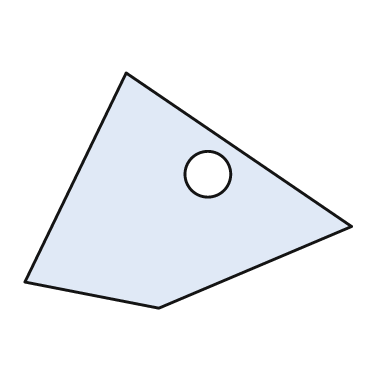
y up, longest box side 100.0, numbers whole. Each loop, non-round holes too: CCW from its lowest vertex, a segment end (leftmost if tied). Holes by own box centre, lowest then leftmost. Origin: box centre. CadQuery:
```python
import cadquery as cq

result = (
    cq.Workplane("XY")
    .moveTo(-9.0, -36.0)
    .lineTo(50.0, -11.0)
    .lineTo(-19.0, 36.0)
    .lineTo(-50.0, -28.0)
    .close()
    .moveTo(6.0, 5.0)
    .circle(7.0)
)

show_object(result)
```